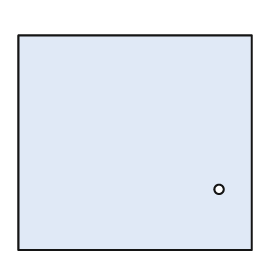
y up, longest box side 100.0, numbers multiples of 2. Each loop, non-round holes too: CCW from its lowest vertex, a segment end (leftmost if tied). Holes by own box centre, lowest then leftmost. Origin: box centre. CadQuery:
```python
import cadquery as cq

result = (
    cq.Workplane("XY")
    .moveTo(-50.0, -46.0)
    .lineTo(50.0, -46.0)
    .lineTo(50.0, 46.0)
    .lineTo(-50.0, 46.0)
    .close()
    .moveTo(36.0, -20.0)
    .circle(2.0)
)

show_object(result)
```